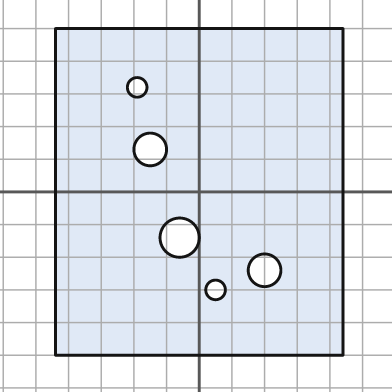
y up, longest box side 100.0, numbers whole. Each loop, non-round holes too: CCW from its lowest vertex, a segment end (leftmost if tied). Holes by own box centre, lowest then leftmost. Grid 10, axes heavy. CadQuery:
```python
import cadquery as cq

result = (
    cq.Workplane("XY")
    .moveTo(-44.0, -50.0)
    .lineTo(44.0, -50.0)
    .lineTo(44.0, 50.0)
    .lineTo(-44.0, 50.0)
    .close()
    .moveTo(5.0, -30.0)
    .circle(3.0)
    .moveTo(20.0, -24.0)
    .circle(5.0)
    .moveTo(-6.0, -14.0)
    .circle(6.0)
    .moveTo(-15.0, 13.0)
    .circle(5.0)
    .moveTo(-19.0, 32.0)
    .circle(3.0)
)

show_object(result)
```